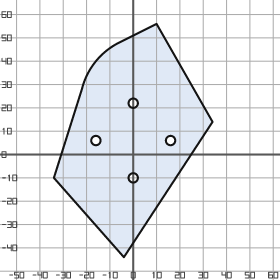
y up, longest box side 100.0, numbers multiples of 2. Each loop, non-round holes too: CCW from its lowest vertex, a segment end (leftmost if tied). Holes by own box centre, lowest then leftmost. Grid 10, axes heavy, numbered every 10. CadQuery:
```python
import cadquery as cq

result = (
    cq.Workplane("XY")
    .moveTo(-4.0, -44.0)
    .lineTo(34.0, 14.0)
    .lineTo(10.0, 56.0)
    .lineTo(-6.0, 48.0)
    .threePointArc((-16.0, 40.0), (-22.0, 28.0))
    .lineTo(-34.0, -10.0)
    .close()
    .moveTo(0.0, -10.0)
    .circle(2.0)
    .moveTo(-16.0, 6.0)
    .circle(2.0)
    .moveTo(16.0, 6.0)
    .circle(2.0)
    .moveTo(0.0, 22.0)
    .circle(2.0)
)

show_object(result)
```